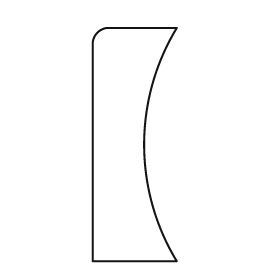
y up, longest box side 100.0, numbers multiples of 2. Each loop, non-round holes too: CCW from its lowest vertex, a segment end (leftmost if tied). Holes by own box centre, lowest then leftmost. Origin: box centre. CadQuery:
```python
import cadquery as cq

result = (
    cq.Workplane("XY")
    .moveTo(-18.0, -50.0)
    .lineTo(18.0, -50.0)
    .threePointArc((4.0, 0.0), (18.0, 50.0))
    .lineTo(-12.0, 50.0)
    .threePointArc((-16.0, 48.0), (-18.0, 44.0))
    .close()
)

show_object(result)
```